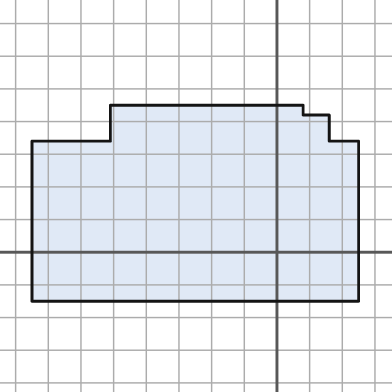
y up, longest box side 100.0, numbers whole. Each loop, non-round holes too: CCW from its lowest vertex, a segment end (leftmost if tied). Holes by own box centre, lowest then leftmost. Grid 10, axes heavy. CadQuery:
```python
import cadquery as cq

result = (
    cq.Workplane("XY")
    .moveTo(-75.0, -15.0)
    .lineTo(25.0, -15.0)
    .lineTo(25.0, 34.0)
    .lineTo(16.0, 34.0)
    .lineTo(16.0, 42.0)
    .lineTo(8.0, 42.0)
    .lineTo(8.0, 45.0)
    .lineTo(-51.0, 45.0)
    .lineTo(-51.0, 34.0)
    .lineTo(-75.0, 34.0)
    .close()
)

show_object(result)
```